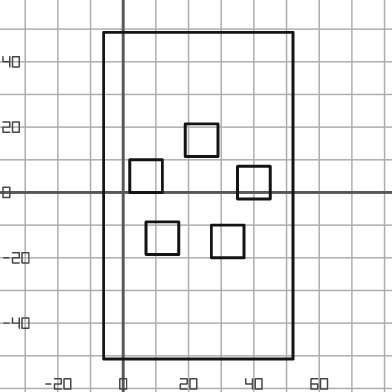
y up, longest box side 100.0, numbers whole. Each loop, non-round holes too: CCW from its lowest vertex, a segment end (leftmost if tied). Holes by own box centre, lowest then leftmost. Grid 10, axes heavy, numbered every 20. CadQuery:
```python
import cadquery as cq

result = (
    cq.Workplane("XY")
    .moveTo(-6.0, -51.0)
    .lineTo(52.0, -51.0)
    .lineTo(52.0, 49.0)
    .lineTo(-6.0, 49.0)
    .close()
    .moveTo(27.0, -20.0)
    .lineTo(37.0, -20.0)
    .lineTo(37.0, -10.0)
    .lineTo(27.0, -10.0)
    .close()
    .moveTo(7.0, -19.0)
    .lineTo(17.0, -19.0)
    .lineTo(17.0, -9.0)
    .lineTo(7.0, -9.0)
    .close()
    .moveTo(35.0, -2.0)
    .lineTo(45.0, -2.0)
    .lineTo(45.0, 8.0)
    .lineTo(35.0, 8.0)
    .close()
    .moveTo(2.0, 0.0)
    .lineTo(12.0, 0.0)
    .lineTo(12.0, 10.0)
    .lineTo(2.0, 10.0)
    .close()
    .moveTo(19.0, 11.0)
    .lineTo(29.0, 11.0)
    .lineTo(29.0, 21.0)
    .lineTo(19.0, 21.0)
    .close()
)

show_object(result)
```